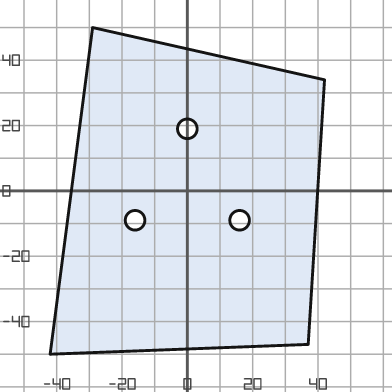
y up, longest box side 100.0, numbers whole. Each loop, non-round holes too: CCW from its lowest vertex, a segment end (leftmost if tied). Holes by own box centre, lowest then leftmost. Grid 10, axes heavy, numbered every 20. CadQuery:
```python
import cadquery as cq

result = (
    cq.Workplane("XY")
    .moveTo(-42.0, -50.0)
    .lineTo(37.0, -47.0)
    .lineTo(42.0, 34.0)
    .lineTo(-29.0, 50.0)
    .close()
    .moveTo(-16.0, -9.0)
    .circle(3.0)
    .moveTo(16.0, -9.0)
    .circle(3.0)
    .moveTo(0.0, 19.0)
    .circle(3.0)
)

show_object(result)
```